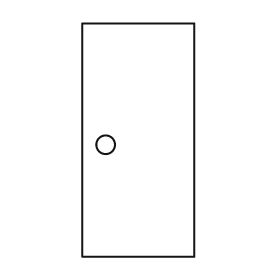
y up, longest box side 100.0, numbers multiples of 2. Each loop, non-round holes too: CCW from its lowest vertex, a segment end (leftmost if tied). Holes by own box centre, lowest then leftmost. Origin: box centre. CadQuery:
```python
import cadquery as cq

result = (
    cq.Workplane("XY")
    .moveTo(-24.0, -50.0)
    .lineTo(24.0, -50.0)
    .lineTo(24.0, 50.0)
    .lineTo(-24.0, 50.0)
    .close()
    .moveTo(-14.0, -2.0)
    .circle(4.0)
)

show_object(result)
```